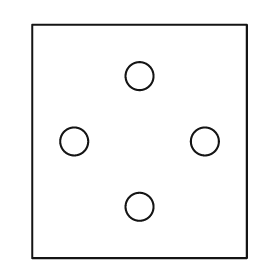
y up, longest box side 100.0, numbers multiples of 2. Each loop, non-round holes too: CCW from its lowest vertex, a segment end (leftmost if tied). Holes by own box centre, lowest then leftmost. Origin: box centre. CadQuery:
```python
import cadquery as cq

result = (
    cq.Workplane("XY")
    .moveTo(-46.0, -50.0)
    .lineTo(46.0, -50.0)
    .lineTo(46.0, 50.0)
    .lineTo(-46.0, 50.0)
    .close()
    .moveTo(0.0, -28.0)
    .circle(6.0)
    .moveTo(-28.0, 0.0)
    .circle(6.0)
    .moveTo(28.0, 0.0)
    .circle(6.0)
    .moveTo(0.0, 28.0)
    .circle(6.0)
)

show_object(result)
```